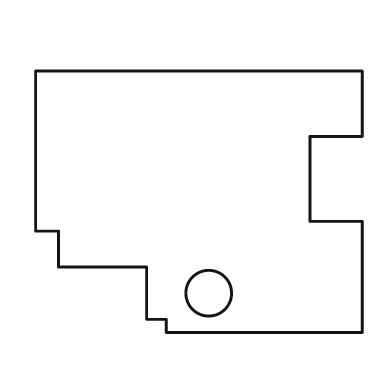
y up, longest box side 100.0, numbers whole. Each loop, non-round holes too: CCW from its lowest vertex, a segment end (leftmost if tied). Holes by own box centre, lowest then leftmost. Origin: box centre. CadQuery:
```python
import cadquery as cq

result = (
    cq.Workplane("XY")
    .moveTo(-10.0, -40.0)
    .lineTo(50.0, -40.0)
    .lineTo(50.0, -6.0)
    .lineTo(34.0, -6.0)
    .lineTo(34.0, 20.0)
    .lineTo(50.0, 20.0)
    .lineTo(50.0, 40.0)
    .lineTo(-50.0, 40.0)
    .lineTo(-50.0, -9.0)
    .lineTo(-43.0, -9.0)
    .lineTo(-43.0, -20.0)
    .lineTo(-16.0, -20.0)
    .lineTo(-16.0, -36.0)
    .lineTo(-10.0, -36.0)
    .close()
    .moveTo(3.0, -28.0)
    .circle(7.0)
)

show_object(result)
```